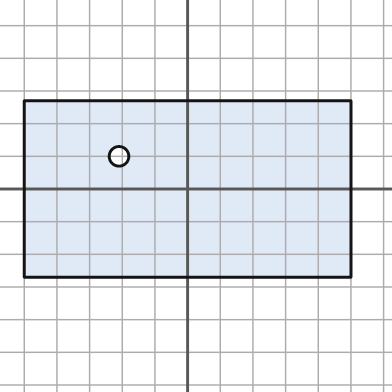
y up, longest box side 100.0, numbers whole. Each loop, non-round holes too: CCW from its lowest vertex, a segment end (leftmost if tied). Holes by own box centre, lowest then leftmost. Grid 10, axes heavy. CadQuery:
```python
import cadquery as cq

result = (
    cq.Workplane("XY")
    .moveTo(-50.0, -27.0)
    .lineTo(50.0, -27.0)
    .lineTo(50.0, 27.0)
    .lineTo(-50.0, 27.0)
    .close()
    .moveTo(-21.0, 10.0)
    .circle(3.0)
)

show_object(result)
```